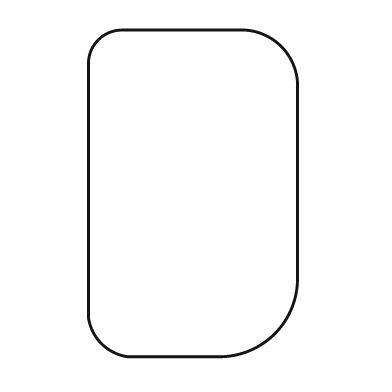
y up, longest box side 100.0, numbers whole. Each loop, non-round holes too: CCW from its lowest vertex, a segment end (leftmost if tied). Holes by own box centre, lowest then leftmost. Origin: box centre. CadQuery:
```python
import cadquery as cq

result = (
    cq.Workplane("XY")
    .moveTo(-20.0, -50.0)
    .lineTo(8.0, -50.0)
    .threePointArc((25.0, -43.0), (32.0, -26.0))
    .lineTo(32.0, 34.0)
    .threePointArc((27.0, 45.0), (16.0, 50.0))
    .lineTo(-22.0, 50.0)
    .threePointArc((-29.0, 47.0), (-32.0, 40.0))
    .lineTo(-32.0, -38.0)
    .threePointArc((-28.0, -46.0), (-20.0, -50.0))
    .close()
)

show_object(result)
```